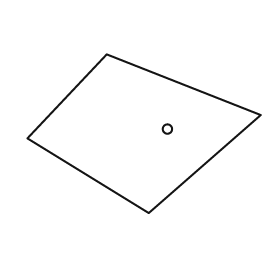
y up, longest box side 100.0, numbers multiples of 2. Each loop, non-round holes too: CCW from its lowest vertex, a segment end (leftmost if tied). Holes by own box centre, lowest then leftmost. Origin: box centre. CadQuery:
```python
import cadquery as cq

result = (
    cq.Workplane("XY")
    .moveTo(2.0, -34.0)
    .lineTo(50.0, 8.0)
    .lineTo(-16.0, 34.0)
    .lineTo(-50.0, -2.0)
    .close()
    .moveTo(10.0, 2.0)
    .circle(2.0)
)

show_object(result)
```